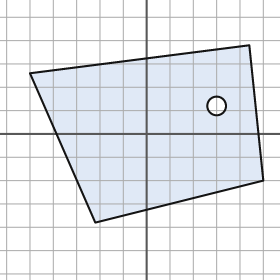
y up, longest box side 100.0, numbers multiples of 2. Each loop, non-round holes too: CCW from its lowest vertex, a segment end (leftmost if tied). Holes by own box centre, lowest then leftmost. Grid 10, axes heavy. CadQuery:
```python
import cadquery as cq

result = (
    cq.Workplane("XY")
    .moveTo(-22.0, -38.0)
    .lineTo(50.0, -20.0)
    .lineTo(44.0, 38.0)
    .lineTo(-50.0, 26.0)
    .close()
    .moveTo(30.0, 12.0)
    .circle(4.0)
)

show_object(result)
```